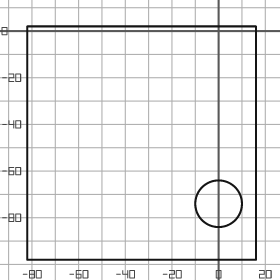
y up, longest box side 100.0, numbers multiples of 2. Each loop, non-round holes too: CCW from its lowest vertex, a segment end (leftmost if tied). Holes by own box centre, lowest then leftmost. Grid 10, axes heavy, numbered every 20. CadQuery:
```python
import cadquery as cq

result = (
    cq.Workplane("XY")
    .moveTo(-82.0, -98.0)
    .lineTo(16.0, -98.0)
    .lineTo(16.0, 2.0)
    .lineTo(-82.0, 2.0)
    .close()
    .moveTo(0.0, -74.0)
    .circle(10.0)
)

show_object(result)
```